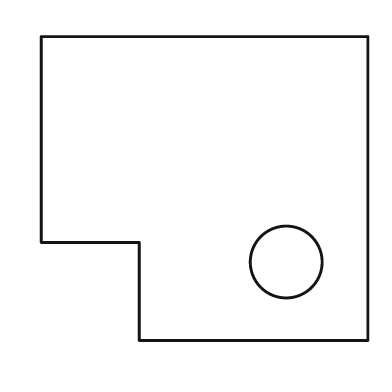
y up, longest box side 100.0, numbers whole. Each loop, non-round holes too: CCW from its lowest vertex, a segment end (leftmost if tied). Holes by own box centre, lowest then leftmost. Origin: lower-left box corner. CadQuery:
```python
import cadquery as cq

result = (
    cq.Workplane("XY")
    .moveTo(30.0, 0.0)
    .lineTo(100.0, 0.0)
    .lineTo(100.0, 93.0)
    .lineTo(0.0, 93.0)
    .lineTo(0.0, 30.0)
    .lineTo(30.0, 30.0)
    .close()
    .moveTo(75.0, 24.0)
    .circle(11.0)
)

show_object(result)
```